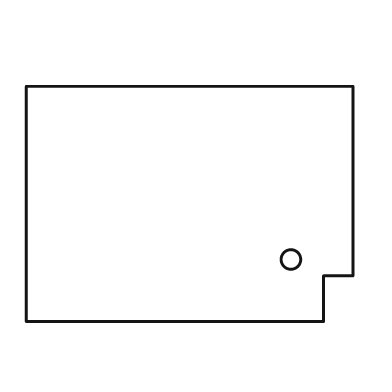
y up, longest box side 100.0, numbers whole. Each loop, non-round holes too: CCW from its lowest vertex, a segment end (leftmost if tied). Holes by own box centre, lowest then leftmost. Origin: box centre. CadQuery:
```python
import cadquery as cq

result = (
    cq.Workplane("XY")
    .moveTo(-50.0, -36.0)
    .lineTo(41.0, -36.0)
    .lineTo(41.0, -22.0)
    .lineTo(50.0, -22.0)
    .lineTo(50.0, 36.0)
    .lineTo(-50.0, 36.0)
    .close()
    .moveTo(31.0, -17.0)
    .circle(3.0)
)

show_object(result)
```